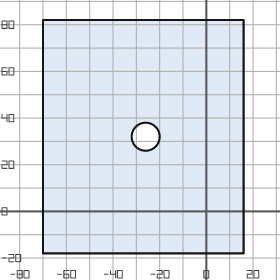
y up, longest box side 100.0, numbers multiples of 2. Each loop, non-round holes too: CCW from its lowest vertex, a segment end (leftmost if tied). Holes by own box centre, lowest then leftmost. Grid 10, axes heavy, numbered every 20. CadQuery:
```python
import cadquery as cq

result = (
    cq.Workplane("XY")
    .moveTo(-70.0, -18.0)
    .lineTo(16.0, -18.0)
    .lineTo(16.0, 82.0)
    .lineTo(-70.0, 82.0)
    .close()
    .moveTo(-26.0, 32.0)
    .circle(6.0)
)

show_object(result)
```